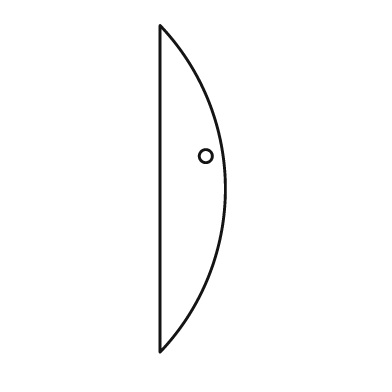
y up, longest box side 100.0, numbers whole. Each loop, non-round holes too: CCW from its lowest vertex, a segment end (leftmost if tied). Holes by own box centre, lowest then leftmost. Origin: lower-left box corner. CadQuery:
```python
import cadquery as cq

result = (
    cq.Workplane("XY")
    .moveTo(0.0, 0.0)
    .threePointArc((20.0, 50.0), (0.0, 100.0))
    .close()
    .moveTo(14.0, 60.0)
    .circle(2.0)
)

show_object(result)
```